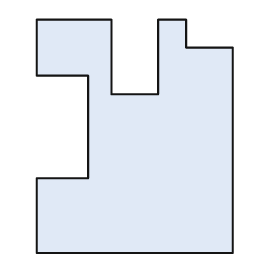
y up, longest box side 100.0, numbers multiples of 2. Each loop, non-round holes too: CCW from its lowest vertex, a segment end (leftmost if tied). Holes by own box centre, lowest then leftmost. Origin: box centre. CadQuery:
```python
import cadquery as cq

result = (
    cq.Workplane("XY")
    .moveTo(-42.0, -50.0)
    .lineTo(42.0, -50.0)
    .lineTo(42.0, 38.0)
    .lineTo(22.0, 38.0)
    .lineTo(22.0, 50.0)
    .lineTo(10.0, 50.0)
    .lineTo(10.0, 18.0)
    .lineTo(-10.0, 18.0)
    .lineTo(-10.0, 50.0)
    .lineTo(-42.0, 50.0)
    .lineTo(-42.0, 26.0)
    .lineTo(-20.0, 26.0)
    .lineTo(-20.0, -18.0)
    .lineTo(-42.0, -18.0)
    .close()
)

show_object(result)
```